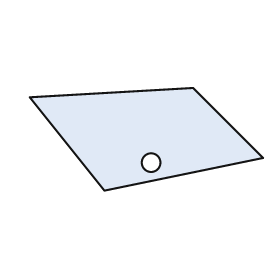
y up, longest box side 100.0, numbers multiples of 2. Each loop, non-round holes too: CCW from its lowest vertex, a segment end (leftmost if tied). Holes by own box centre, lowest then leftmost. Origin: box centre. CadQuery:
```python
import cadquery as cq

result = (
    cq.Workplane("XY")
    .moveTo(-18.0, -22.0)
    .lineTo(50.0, -8.0)
    .lineTo(20.0, 22.0)
    .lineTo(-50.0, 18.0)
    .close()
    .moveTo(2.0, -10.0)
    .circle(4.0)
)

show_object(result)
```